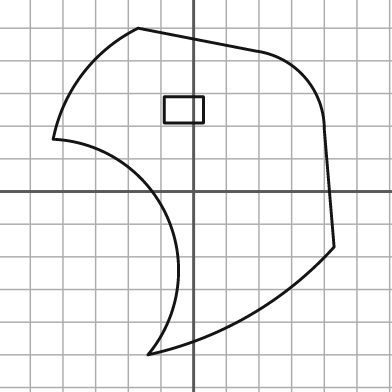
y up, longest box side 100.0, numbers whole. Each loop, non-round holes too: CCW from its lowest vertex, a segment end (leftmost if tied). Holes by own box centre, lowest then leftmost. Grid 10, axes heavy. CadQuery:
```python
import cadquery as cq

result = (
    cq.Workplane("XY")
    .moveTo(-14.0, -50.0)
    .threePointArc((17.0, -38.0), (43.0, -17.0))
    .lineTo(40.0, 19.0)
    .threePointArc((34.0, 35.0), (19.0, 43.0))
    .lineTo(-17.0, 50.0)
    .threePointArc((-34.0, 36.0), (-43.0, 16.0))
    .threePointArc((-8.0, -8.0), (-14.0, -50.0))
    .close()
    .moveTo(-9.0, 21.0)
    .lineTo(3.0, 21.0)
    .lineTo(3.0, 29.0)
    .lineTo(-9.0, 29.0)
    .close()
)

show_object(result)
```